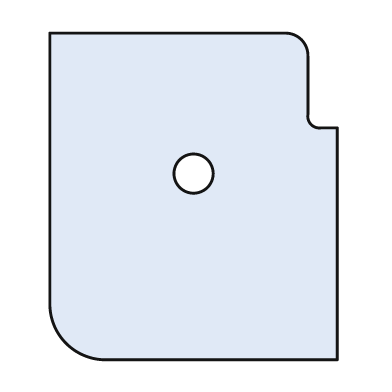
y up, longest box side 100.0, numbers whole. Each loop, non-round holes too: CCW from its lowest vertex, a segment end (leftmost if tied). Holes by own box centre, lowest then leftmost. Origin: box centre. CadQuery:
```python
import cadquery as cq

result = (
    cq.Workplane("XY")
    .moveTo(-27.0, -50.0)
    .lineTo(44.0, -50.0)
    .lineTo(44.0, 21.0)
    .lineTo(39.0, 21.0)
    .threePointArc((36.0, 22.0), (35.0, 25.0))
    .lineTo(35.0, 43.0)
    .threePointArc((33.0, 48.0), (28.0, 50.0))
    .lineTo(-44.0, 50.0)
    .lineTo(-44.0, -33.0)
    .threePointArc((-39.0, -45.0), (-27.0, -50.0))
    .close()
    .moveTo(0.0, 7.0)
    .circle(6.0)
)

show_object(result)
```